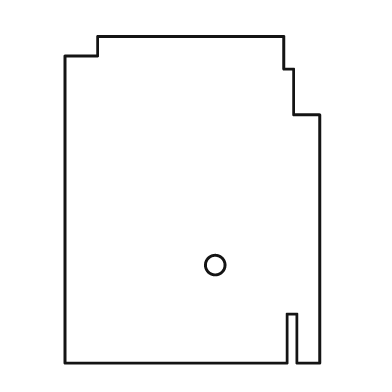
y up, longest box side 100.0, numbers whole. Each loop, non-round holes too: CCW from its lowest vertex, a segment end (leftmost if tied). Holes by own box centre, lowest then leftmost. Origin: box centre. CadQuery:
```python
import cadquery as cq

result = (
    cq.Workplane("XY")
    .moveTo(-39.0, -50.0)
    .lineTo(29.0, -50.0)
    .lineTo(29.0, -35.0)
    .lineTo(32.0, -35.0)
    .lineTo(32.0, -50.0)
    .lineTo(39.0, -50.0)
    .lineTo(39.0, 26.0)
    .lineTo(31.0, 26.0)
    .lineTo(31.0, 40.0)
    .lineTo(28.0, 40.0)
    .lineTo(28.0, 50.0)
    .lineTo(-29.0, 50.0)
    .lineTo(-29.0, 44.0)
    .lineTo(-39.0, 44.0)
    .close()
    .moveTo(7.0, -20.0)
    .circle(3.0)
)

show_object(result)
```